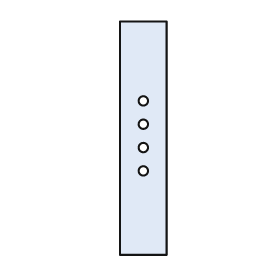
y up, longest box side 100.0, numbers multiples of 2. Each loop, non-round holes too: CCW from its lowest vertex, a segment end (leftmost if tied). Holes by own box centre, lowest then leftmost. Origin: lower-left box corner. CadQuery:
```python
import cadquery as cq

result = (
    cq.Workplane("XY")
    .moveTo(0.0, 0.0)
    .lineTo(20.0, 0.0)
    .lineTo(20.0, 100.0)
    .lineTo(0.0, 100.0)
    .close()
    .moveTo(10.0, 36.0)
    .circle(2.0)
    .moveTo(10.0, 46.0)
    .circle(2.0)
    .moveTo(10.0, 56.0)
    .circle(2.0)
    .moveTo(10.0, 66.0)
    .circle(2.0)
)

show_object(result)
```